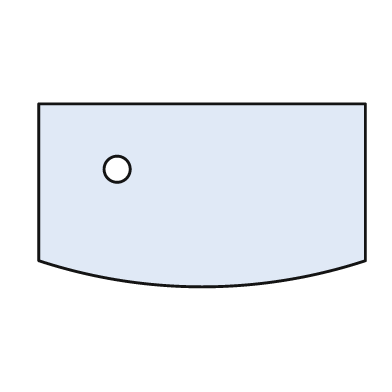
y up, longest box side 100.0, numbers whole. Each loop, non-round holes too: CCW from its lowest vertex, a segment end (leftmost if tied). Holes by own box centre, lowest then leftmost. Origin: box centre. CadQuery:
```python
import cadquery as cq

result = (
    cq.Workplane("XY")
    .moveTo(-50.0, -20.0)
    .threePointArc((0.0, -28.0), (50.0, -20.0))
    .lineTo(50.0, 28.0)
    .lineTo(-50.0, 28.0)
    .close()
    .moveTo(-26.0, 8.0)
    .circle(4.0)
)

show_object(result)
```